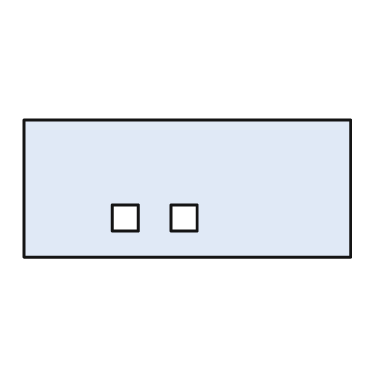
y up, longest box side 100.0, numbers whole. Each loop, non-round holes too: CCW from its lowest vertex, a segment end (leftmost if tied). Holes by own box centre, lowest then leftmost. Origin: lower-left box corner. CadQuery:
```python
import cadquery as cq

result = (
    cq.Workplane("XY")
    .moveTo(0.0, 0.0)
    .lineTo(100.0, 0.0)
    .lineTo(100.0, 42.0)
    .lineTo(0.0, 42.0)
    .close()
    .moveTo(27.0, 8.0)
    .lineTo(35.0, 8.0)
    .lineTo(35.0, 16.0)
    .lineTo(27.0, 16.0)
    .close()
    .moveTo(45.0, 8.0)
    .lineTo(53.0, 8.0)
    .lineTo(53.0, 16.0)
    .lineTo(45.0, 16.0)
    .close()
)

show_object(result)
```